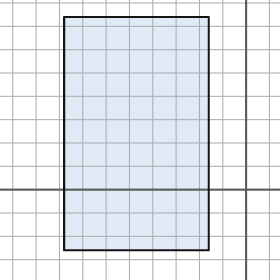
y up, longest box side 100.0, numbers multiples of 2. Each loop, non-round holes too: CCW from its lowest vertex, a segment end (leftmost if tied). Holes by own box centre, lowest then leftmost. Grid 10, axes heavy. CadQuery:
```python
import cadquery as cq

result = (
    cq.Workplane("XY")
    .moveTo(-78.0, -26.0)
    .lineTo(-16.0, -26.0)
    .lineTo(-16.0, 74.0)
    .lineTo(-78.0, 74.0)
    .close()
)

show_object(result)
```